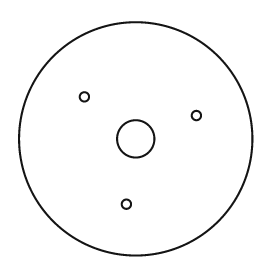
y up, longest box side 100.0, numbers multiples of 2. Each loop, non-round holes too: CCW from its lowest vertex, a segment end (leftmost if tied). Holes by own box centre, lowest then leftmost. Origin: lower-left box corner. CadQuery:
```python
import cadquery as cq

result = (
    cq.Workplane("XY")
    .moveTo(50.0, 50.0)
    .circle(50.0)
    .moveTo(46.0, 22.0)
    .circle(2.0)
    .moveTo(50.0, 50.0)
    .circle(8.0)
    .moveTo(76.0, 60.0)
    .circle(2.0)
    .moveTo(28.0, 68.0)
    .circle(2.0)
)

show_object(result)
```